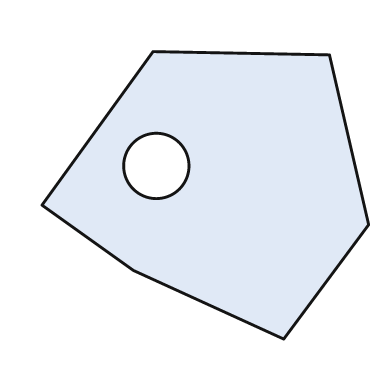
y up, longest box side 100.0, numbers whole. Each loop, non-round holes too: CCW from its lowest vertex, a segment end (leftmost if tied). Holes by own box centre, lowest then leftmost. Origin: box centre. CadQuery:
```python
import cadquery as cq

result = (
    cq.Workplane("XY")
    .moveTo(24.0, -44.0)
    .lineTo(50.0, -9.0)
    .lineTo(38.0, 43.0)
    .lineTo(-16.0, 44.0)
    .lineTo(-50.0, -3.0)
    .lineTo(-22.0, -23.0)
    .close()
    .moveTo(-15.0, 9.0)
    .circle(10.0)
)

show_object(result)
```